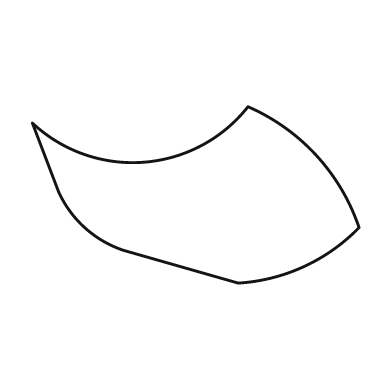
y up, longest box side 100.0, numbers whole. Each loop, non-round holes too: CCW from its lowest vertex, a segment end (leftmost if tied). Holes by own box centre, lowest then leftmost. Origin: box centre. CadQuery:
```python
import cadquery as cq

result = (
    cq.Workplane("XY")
    .moveTo(13.0, -27.0)
    .threePointArc((33.0, -22.0), (50.0, -10.0))
    .threePointArc((37.0, 12.0), (16.0, 27.0))
    .threePointArc((-16.0, 10.0), (-50.0, 22.0))
    .lineTo(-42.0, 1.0)
    .threePointArc((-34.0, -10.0), (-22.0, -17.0))
    .close()
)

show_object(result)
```